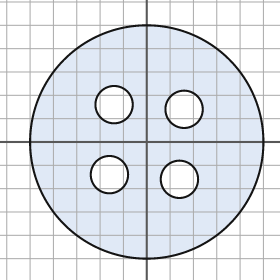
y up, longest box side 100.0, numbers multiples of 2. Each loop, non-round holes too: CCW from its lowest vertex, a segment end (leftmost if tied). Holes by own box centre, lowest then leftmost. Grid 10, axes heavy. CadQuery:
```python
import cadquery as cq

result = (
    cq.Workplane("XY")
    .moveTo(0.0, 0.0)
    .circle(50.0)
    .moveTo(14.0, -16.0)
    .circle(8.0)
    .moveTo(-16.0, -14.0)
    .circle(8.0)
    .moveTo(16.0, 14.0)
    .circle(8.0)
    .moveTo(-14.0, 16.0)
    .circle(8.0)
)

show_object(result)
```